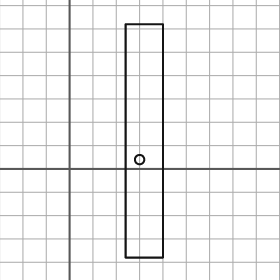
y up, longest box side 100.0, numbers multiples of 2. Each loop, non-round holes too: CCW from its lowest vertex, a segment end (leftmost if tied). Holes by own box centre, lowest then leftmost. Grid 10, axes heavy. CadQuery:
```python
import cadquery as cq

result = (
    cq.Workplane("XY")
    .moveTo(24.0, -38.0)
    .lineTo(40.0, -38.0)
    .lineTo(40.0, 62.0)
    .lineTo(24.0, 62.0)
    .close()
    .moveTo(30.0, 4.0)
    .circle(2.0)
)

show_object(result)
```